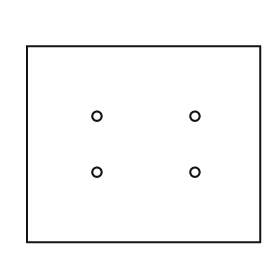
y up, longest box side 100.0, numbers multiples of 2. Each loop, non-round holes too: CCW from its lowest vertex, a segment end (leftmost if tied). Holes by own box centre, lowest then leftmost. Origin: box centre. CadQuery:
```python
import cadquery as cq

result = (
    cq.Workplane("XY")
    .moveTo(-50.0, -42.0)
    .lineTo(50.0, -42.0)
    .lineTo(50.0, 42.0)
    .lineTo(-50.0, 42.0)
    .close()
    .moveTo(-20.0, -12.0)
    .circle(2.0)
    .moveTo(22.0, -12.0)
    .circle(2.0)
    .moveTo(-20.0, 12.0)
    .circle(2.0)
    .moveTo(22.0, 12.0)
    .circle(2.0)
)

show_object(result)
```